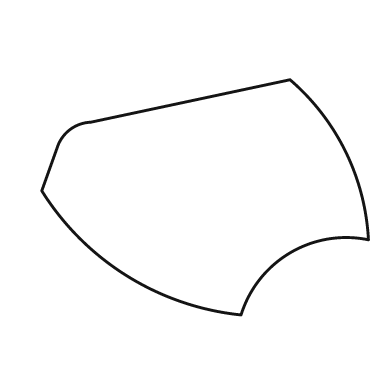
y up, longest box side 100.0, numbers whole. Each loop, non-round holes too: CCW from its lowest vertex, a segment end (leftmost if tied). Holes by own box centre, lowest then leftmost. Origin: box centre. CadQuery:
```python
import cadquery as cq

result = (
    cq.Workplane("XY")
    .moveTo(11.0, -36.0)
    .threePointArc((26.0, -17.0), (50.0, -13.0))
    .threePointArc((43.0, 14.0), (26.0, 36.0))
    .lineTo(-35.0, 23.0)
    .threePointArc((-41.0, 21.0), (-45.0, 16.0))
    .lineTo(-50.0, 2.0)
    .threePointArc((-24.0, -24.0), (11.0, -36.0))
    .close()
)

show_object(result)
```